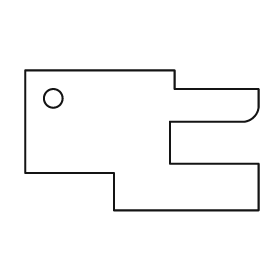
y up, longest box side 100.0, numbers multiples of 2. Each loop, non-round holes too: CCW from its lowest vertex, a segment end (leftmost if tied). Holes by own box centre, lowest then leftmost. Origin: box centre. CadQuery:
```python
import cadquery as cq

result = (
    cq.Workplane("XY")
    .moveTo(-12.0, -30.0)
    .lineTo(50.0, -30.0)
    .lineTo(50.0, -10.0)
    .lineTo(12.0, -10.0)
    .lineTo(12.0, 8.0)
    .lineTo(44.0, 8.0)
    .threePointArc((48.0, 10.0), (50.0, 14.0))
    .lineTo(50.0, 22.0)
    .lineTo(14.0, 22.0)
    .lineTo(14.0, 30.0)
    .lineTo(-50.0, 30.0)
    .lineTo(-50.0, -14.0)
    .lineTo(-12.0, -14.0)
    .close()
    .moveTo(-38.0, 18.0)
    .circle(4.0)
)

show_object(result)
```